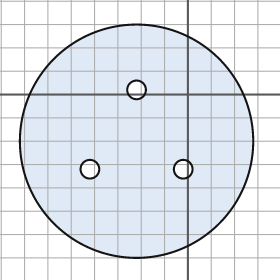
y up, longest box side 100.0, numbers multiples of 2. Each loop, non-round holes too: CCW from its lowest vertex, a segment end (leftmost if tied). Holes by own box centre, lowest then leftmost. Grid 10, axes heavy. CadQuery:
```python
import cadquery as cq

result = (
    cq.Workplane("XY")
    .moveTo(-22.0, -20.0)
    .circle(50.0)
    .moveTo(-42.0, -32.0)
    .circle(4.0)
    .moveTo(-2.0, -32.0)
    .circle(4.0)
    .moveTo(-22.0, 2.0)
    .circle(4.0)
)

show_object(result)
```